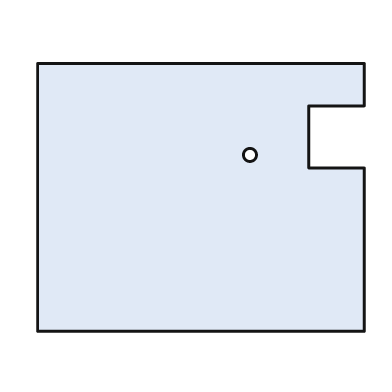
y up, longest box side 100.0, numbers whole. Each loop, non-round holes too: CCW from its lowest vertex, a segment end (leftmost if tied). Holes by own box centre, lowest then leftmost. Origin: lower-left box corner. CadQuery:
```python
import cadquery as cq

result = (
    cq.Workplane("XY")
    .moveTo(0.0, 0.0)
    .lineTo(100.0, 0.0)
    .lineTo(100.0, 50.0)
    .lineTo(83.0, 50.0)
    .lineTo(83.0, 69.0)
    .lineTo(100.0, 69.0)
    .lineTo(100.0, 82.0)
    .lineTo(0.0, 82.0)
    .close()
    .moveTo(65.0, 54.0)
    .circle(2.0)
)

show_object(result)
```